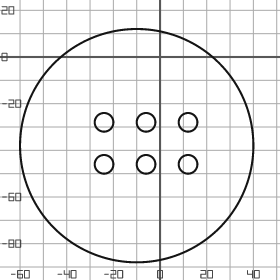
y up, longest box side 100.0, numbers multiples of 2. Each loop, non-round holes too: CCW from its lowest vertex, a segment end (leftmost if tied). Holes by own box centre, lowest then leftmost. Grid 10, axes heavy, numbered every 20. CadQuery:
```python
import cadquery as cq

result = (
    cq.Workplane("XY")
    .moveTo(-10.0, -38.0)
    .circle(50.0)
    .moveTo(-24.0, -46.0)
    .circle(4.0)
    .moveTo(-6.0, -46.0)
    .circle(4.0)
    .moveTo(12.0, -46.0)
    .circle(4.0)
    .moveTo(-24.0, -28.0)
    .circle(4.0)
    .moveTo(-6.0, -28.0)
    .circle(4.0)
    .moveTo(12.0, -28.0)
    .circle(4.0)
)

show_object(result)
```